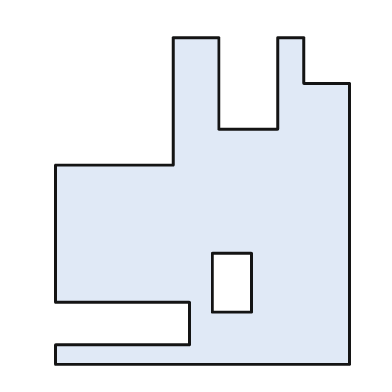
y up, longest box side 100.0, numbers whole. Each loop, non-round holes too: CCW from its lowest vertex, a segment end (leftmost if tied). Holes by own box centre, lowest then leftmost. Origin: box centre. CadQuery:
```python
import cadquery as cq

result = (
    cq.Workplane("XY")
    .moveTo(-45.0, -50.0)
    .lineTo(45.0, -50.0)
    .lineTo(45.0, 36.0)
    .lineTo(31.0, 36.0)
    .lineTo(31.0, 50.0)
    .lineTo(23.0, 50.0)
    .lineTo(23.0, 22.0)
    .lineTo(5.0, 22.0)
    .lineTo(5.0, 50.0)
    .lineTo(-9.0, 50.0)
    .lineTo(-9.0, 11.0)
    .lineTo(-45.0, 11.0)
    .lineTo(-45.0, -31.0)
    .lineTo(-4.0, -31.0)
    .lineTo(-4.0, -44.0)
    .lineTo(-45.0, -44.0)
    .close()
    .moveTo(3.0, -34.0)
    .lineTo(15.0, -34.0)
    .lineTo(15.0, -16.0)
    .lineTo(3.0, -16.0)
    .close()
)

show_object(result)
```